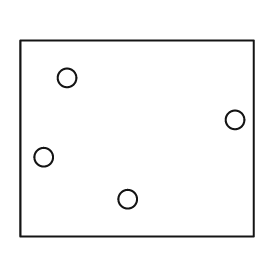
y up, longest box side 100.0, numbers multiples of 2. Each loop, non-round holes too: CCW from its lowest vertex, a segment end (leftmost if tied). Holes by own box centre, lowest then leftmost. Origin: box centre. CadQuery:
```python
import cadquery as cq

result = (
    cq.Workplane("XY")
    .moveTo(-50.0, -42.0)
    .lineTo(50.0, -42.0)
    .lineTo(50.0, 42.0)
    .lineTo(-50.0, 42.0)
    .close()
    .moveTo(-4.0, -26.0)
    .circle(4.0)
    .moveTo(-40.0, -8.0)
    .circle(4.0)
    .moveTo(42.0, 8.0)
    .circle(4.0)
    .moveTo(-30.0, 26.0)
    .circle(4.0)
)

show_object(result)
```